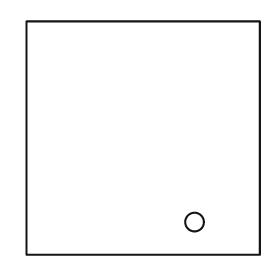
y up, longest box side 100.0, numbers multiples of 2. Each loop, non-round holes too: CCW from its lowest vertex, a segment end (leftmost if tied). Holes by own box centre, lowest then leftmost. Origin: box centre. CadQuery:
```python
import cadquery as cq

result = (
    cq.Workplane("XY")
    .moveTo(-50.0, -50.0)
    .lineTo(50.0, -50.0)
    .lineTo(50.0, 50.0)
    .lineTo(-50.0, 50.0)
    .close()
    .moveTo(22.0, -36.0)
    .circle(4.0)
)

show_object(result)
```